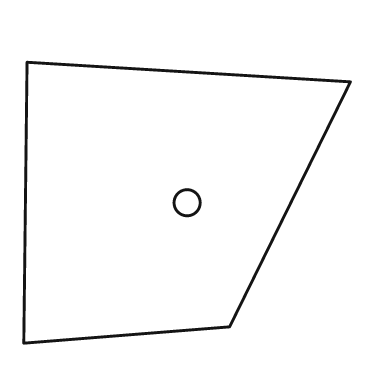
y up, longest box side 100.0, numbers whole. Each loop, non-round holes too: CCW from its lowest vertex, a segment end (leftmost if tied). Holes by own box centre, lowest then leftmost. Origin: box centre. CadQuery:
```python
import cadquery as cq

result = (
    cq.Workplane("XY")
    .moveTo(-50.0, -43.0)
    .lineTo(13.0, -38.0)
    .lineTo(50.0, 37.0)
    .lineTo(-49.0, 43.0)
    .close()
    .moveTo(0.0, 0.0)
    .circle(4.0)
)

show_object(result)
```